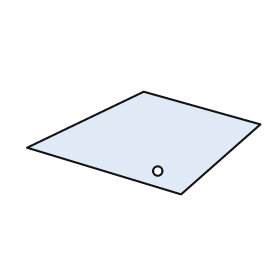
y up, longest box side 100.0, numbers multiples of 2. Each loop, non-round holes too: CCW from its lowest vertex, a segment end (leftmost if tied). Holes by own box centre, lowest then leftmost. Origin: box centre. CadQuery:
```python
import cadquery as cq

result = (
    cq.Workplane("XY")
    .moveTo(16.0, -22.0)
    .lineTo(50.0, 8.0)
    .lineTo(0.0, 22.0)
    .lineTo(-50.0, -2.0)
    .close()
    .moveTo(6.0, -12.0)
    .circle(2.0)
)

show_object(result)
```